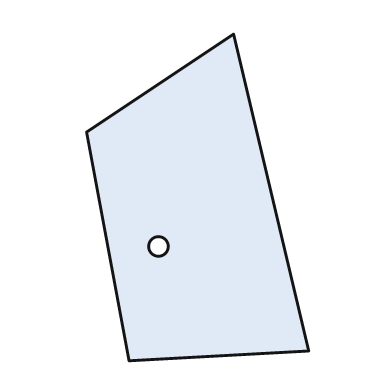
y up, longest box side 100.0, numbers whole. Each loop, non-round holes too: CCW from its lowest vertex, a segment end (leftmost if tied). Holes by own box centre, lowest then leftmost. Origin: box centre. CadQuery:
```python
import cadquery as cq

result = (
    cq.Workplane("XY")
    .moveTo(-21.0, -50.0)
    .lineTo(34.0, -47.0)
    .lineTo(11.0, 50.0)
    .lineTo(-34.0, 20.0)
    .close()
    .moveTo(-12.0, -15.0)
    .circle(3.0)
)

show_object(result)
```